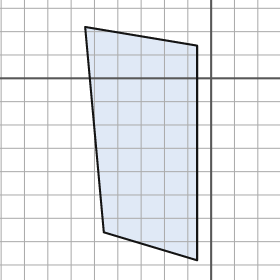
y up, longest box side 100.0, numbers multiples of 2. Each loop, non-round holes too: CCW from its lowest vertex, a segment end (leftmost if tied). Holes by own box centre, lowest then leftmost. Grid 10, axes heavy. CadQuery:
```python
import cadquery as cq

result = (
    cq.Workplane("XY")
    .moveTo(-6.0, -78.0)
    .lineTo(-6.0, 14.0)
    .lineTo(-54.0, 22.0)
    .lineTo(-46.0, -66.0)
    .close()
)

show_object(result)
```